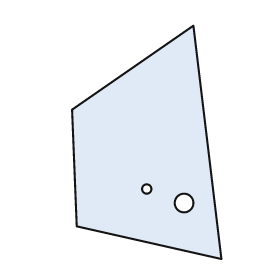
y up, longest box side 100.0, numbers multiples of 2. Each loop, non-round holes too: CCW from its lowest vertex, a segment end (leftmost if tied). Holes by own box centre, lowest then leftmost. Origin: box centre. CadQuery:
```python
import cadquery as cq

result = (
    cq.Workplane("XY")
    .moveTo(32.0, -50.0)
    .lineTo(20.0, 50.0)
    .lineTo(-32.0, 14.0)
    .lineTo(-30.0, -36.0)
    .close()
    .moveTo(16.0, -26.0)
    .circle(4.0)
    .moveTo(0.0, -20.0)
    .circle(2.0)
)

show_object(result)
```